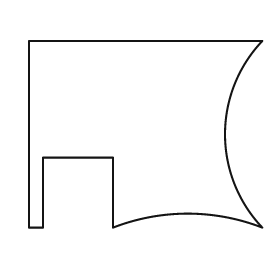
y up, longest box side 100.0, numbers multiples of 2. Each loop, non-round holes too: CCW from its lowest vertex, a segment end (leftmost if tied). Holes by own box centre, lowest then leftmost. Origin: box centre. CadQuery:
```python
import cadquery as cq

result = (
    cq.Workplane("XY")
    .moveTo(-50.0, -40.0)
    .lineTo(-44.0, -40.0)
    .lineTo(-44.0, -10.0)
    .lineTo(-14.0, -10.0)
    .lineTo(-14.0, -40.0)
    .threePointArc((18.0, -34.0), (50.0, -40.0))
    .threePointArc((34.0, 0.0), (50.0, 40.0))
    .lineTo(-50.0, 40.0)
    .close()
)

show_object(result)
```